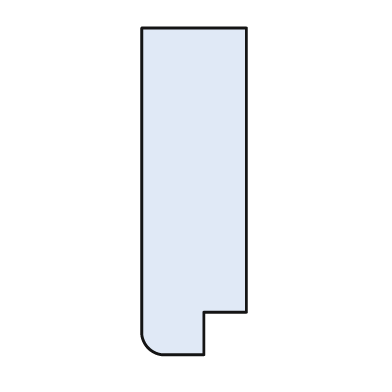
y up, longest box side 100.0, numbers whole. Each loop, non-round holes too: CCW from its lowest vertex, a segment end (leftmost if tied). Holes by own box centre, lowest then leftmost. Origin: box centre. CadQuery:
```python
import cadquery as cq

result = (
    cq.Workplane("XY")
    .moveTo(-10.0, -50.0)
    .lineTo(3.0, -50.0)
    .lineTo(3.0, -37.0)
    .lineTo(16.0, -37.0)
    .lineTo(16.0, 50.0)
    .lineTo(-16.0, 50.0)
    .lineTo(-16.0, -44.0)
    .threePointArc((-14.0, -48.0), (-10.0, -50.0))
    .close()
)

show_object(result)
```